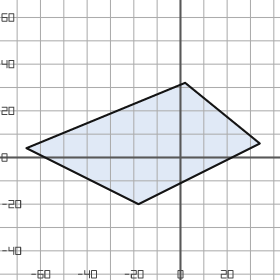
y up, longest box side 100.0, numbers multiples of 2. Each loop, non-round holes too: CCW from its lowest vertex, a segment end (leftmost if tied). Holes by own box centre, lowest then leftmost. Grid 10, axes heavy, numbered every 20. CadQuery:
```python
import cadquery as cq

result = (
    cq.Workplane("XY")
    .moveTo(-18.0, -20.0)
    .lineTo(34.0, 6.0)
    .lineTo(2.0, 32.0)
    .lineTo(-66.0, 4.0)
    .close()
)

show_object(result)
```